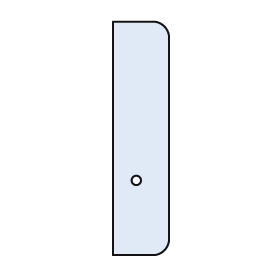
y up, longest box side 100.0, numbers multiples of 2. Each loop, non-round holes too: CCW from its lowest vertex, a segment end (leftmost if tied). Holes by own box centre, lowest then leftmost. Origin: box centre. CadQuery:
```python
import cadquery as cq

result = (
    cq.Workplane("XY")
    .moveTo(-12.0, -50.0)
    .lineTo(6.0, -50.0)
    .threePointArc((10.0, -48.0), (12.0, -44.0))
    .lineTo(12.0, 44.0)
    .threePointArc((10.0, 48.0), (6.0, 50.0))
    .lineTo(-12.0, 50.0)
    .close()
    .moveTo(-2.0, -18.0)
    .circle(2.0)
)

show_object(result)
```